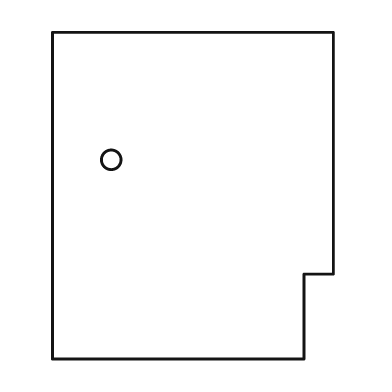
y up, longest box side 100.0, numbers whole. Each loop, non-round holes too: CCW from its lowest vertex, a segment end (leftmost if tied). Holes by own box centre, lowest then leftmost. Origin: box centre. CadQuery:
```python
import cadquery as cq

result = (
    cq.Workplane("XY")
    .moveTo(-43.0, -50.0)
    .lineTo(34.0, -50.0)
    .lineTo(34.0, -24.0)
    .lineTo(43.0, -24.0)
    .lineTo(43.0, 50.0)
    .lineTo(-43.0, 50.0)
    .close()
    .moveTo(-25.0, 11.0)
    .circle(3.0)
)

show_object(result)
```